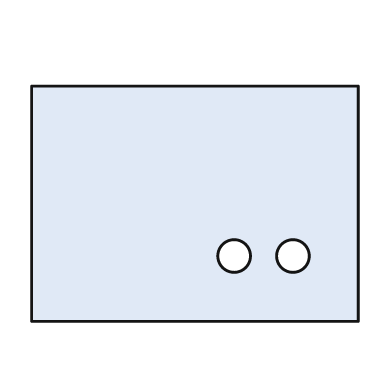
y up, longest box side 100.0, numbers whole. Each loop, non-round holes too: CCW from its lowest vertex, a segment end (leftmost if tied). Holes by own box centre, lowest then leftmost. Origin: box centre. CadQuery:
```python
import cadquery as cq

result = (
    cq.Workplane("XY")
    .moveTo(-50.0, -36.0)
    .lineTo(50.0, -36.0)
    .lineTo(50.0, 36.0)
    .lineTo(-50.0, 36.0)
    .close()
    .moveTo(12.0, -16.0)
    .circle(5.0)
    .moveTo(30.0, -16.0)
    .circle(5.0)
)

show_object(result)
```